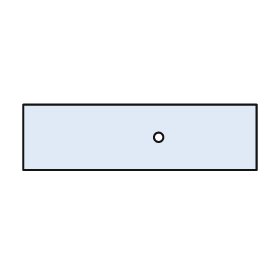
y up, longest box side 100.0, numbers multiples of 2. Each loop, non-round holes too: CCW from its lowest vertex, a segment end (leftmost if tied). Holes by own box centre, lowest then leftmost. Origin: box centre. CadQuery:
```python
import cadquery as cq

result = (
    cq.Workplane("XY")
    .moveTo(-50.0, -14.0)
    .lineTo(50.0, -14.0)
    .lineTo(50.0, 14.0)
    .lineTo(-50.0, 14.0)
    .close()
    .moveTo(8.0, 0.0)
    .circle(2.0)
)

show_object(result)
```